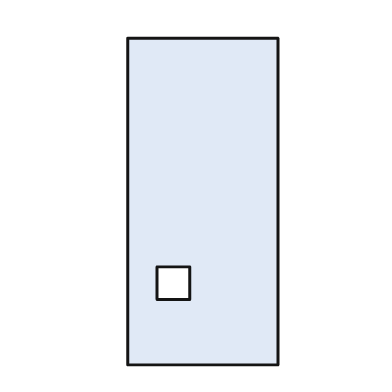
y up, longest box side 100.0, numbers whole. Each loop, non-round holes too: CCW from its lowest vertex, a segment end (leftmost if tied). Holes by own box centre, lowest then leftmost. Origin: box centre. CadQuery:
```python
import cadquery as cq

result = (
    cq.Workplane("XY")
    .moveTo(-23.0, -50.0)
    .lineTo(23.0, -50.0)
    .lineTo(23.0, 50.0)
    .lineTo(-23.0, 50.0)
    .close()
    .moveTo(-14.0, -30.0)
    .lineTo(-4.0, -30.0)
    .lineTo(-4.0, -20.0)
    .lineTo(-14.0, -20.0)
    .close()
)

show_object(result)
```